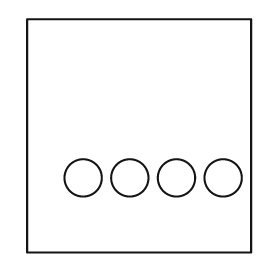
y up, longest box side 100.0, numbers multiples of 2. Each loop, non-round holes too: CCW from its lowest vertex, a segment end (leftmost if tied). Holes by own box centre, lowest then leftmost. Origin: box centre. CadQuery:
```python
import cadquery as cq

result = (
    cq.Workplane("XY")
    .moveTo(-48.0, -50.0)
    .lineTo(48.0, -50.0)
    .lineTo(48.0, 50.0)
    .lineTo(-48.0, 50.0)
    .close()
    .moveTo(-24.0, -18.0)
    .circle(8.0)
    .moveTo(-4.0, -18.0)
    .circle(8.0)
    .moveTo(16.0, -18.0)
    .circle(8.0)
    .moveTo(36.0, -18.0)
    .circle(8.0)
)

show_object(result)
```